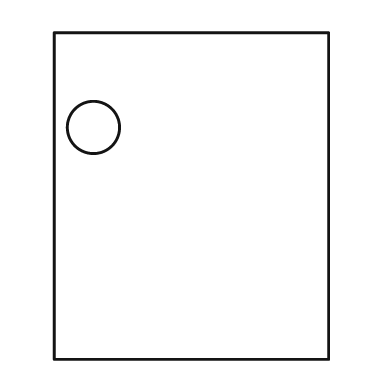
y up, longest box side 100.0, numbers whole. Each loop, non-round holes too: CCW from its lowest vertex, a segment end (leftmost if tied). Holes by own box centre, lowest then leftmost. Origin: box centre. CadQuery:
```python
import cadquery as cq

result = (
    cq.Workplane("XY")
    .moveTo(-42.0, -50.0)
    .lineTo(42.0, -50.0)
    .lineTo(42.0, 50.0)
    .lineTo(-42.0, 50.0)
    .close()
    .moveTo(-30.0, 21.0)
    .circle(8.0)
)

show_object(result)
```